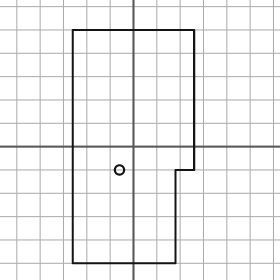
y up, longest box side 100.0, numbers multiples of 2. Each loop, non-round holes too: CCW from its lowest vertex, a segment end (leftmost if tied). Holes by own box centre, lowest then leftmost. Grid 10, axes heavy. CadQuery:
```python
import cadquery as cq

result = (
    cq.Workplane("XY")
    .moveTo(-26.0, -50.0)
    .lineTo(18.0, -50.0)
    .lineTo(18.0, -10.0)
    .lineTo(26.0, -10.0)
    .lineTo(26.0, 50.0)
    .lineTo(-26.0, 50.0)
    .close()
    .moveTo(-6.0, -10.0)
    .circle(2.0)
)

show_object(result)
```